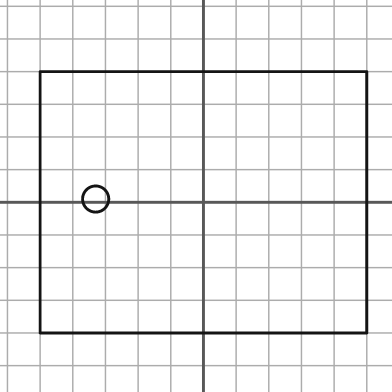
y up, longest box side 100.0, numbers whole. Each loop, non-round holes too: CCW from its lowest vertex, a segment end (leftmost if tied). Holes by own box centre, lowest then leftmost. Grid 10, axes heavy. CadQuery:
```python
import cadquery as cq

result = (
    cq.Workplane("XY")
    .moveTo(-50.0, -40.0)
    .lineTo(50.0, -40.0)
    .lineTo(50.0, 40.0)
    .lineTo(-50.0, 40.0)
    .close()
    .moveTo(-33.0, 1.0)
    .circle(4.0)
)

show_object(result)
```